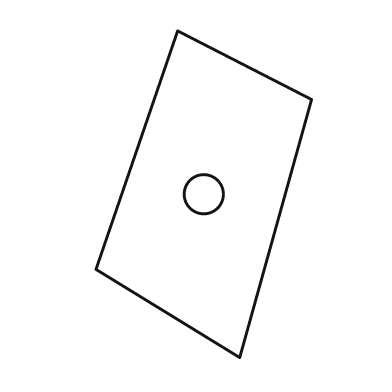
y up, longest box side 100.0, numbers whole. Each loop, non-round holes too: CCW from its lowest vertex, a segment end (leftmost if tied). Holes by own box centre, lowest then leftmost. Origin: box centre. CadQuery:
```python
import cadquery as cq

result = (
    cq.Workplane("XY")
    .moveTo(11.0, -50.0)
    .lineTo(33.0, 29.0)
    .lineTo(-8.0, 50.0)
    .lineTo(-33.0, -23.0)
    .close()
    .moveTo(0.0, 0.0)
    .circle(6.0)
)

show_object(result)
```